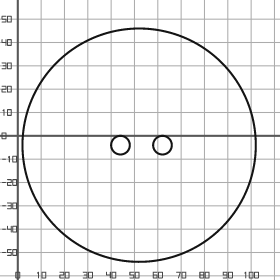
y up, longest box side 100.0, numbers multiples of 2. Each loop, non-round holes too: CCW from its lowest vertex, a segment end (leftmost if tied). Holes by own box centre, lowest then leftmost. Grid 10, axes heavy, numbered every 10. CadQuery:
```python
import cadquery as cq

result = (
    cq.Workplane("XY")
    .moveTo(52.0, -4.0)
    .circle(50.0)
    .moveTo(44.0, -4.0)
    .circle(4.0)
    .moveTo(62.0, -4.0)
    .circle(4.0)
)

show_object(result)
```